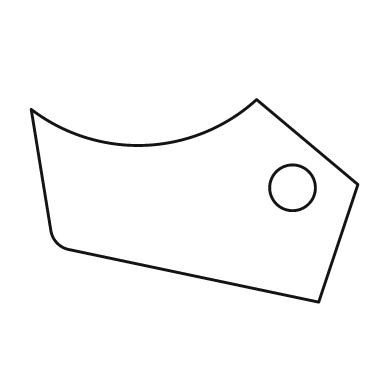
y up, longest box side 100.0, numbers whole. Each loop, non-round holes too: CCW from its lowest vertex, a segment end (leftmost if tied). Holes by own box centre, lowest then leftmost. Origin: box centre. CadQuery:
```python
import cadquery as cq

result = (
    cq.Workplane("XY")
    .moveTo(38.0, -31.0)
    .lineTo(50.0, 5.0)
    .lineTo(19.0, 31.0)
    .threePointArc((-15.0, 17.0), (-50.0, 28.0))
    .lineTo(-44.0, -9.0)
    .threePointArc((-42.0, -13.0), (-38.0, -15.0))
    .close()
    .moveTo(30.0, 4.0)
    .circle(7.0)
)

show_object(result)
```